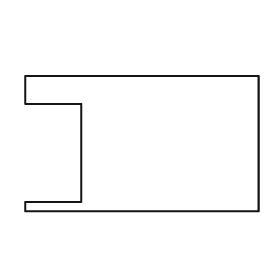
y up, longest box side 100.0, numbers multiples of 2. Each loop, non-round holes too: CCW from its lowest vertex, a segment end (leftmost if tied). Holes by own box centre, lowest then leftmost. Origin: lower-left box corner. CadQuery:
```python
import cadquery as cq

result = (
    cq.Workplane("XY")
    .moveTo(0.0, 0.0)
    .lineTo(100.0, 0.0)
    .lineTo(100.0, 58.0)
    .lineTo(0.0, 58.0)
    .lineTo(0.0, 46.0)
    .lineTo(24.0, 46.0)
    .lineTo(24.0, 4.0)
    .lineTo(0.0, 4.0)
    .close()
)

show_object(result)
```